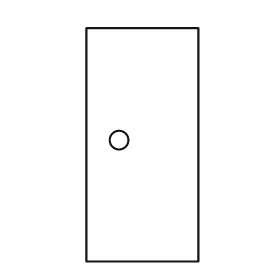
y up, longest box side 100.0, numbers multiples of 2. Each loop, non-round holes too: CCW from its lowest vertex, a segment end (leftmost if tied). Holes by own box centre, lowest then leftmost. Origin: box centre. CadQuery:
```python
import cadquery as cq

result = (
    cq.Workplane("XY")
    .moveTo(-24.0, -50.0)
    .lineTo(24.0, -50.0)
    .lineTo(24.0, 50.0)
    .lineTo(-24.0, 50.0)
    .close()
    .moveTo(-10.0, 2.0)
    .circle(4.0)
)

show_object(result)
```